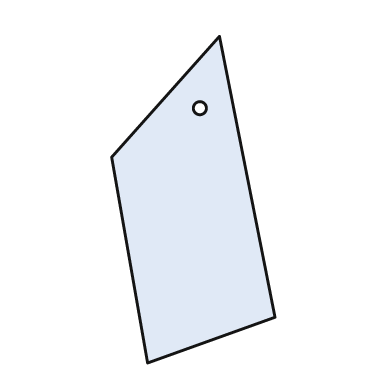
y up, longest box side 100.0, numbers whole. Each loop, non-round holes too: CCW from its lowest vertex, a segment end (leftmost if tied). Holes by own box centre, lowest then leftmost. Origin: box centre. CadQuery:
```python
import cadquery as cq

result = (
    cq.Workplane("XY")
    .moveTo(-14.0, -50.0)
    .lineTo(25.0, -36.0)
    .lineTo(8.0, 50.0)
    .lineTo(-25.0, 13.0)
    .close()
    .moveTo(2.0, 28.0)
    .circle(2.0)
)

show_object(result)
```